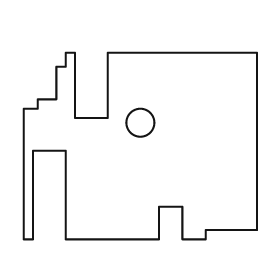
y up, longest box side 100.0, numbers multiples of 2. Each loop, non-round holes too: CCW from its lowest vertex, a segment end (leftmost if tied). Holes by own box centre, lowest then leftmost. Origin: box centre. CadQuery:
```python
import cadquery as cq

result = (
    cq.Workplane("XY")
    .moveTo(-50.0, -40.0)
    .lineTo(-46.0, -40.0)
    .lineTo(-46.0, -2.0)
    .lineTo(-32.0, -2.0)
    .lineTo(-32.0, -40.0)
    .lineTo(8.0, -40.0)
    .lineTo(8.0, -26.0)
    .lineTo(18.0, -26.0)
    .lineTo(18.0, -40.0)
    .lineTo(28.0, -40.0)
    .lineTo(28.0, -36.0)
    .lineTo(50.0, -36.0)
    .lineTo(50.0, 40.0)
    .lineTo(-14.0, 40.0)
    .lineTo(-14.0, 12.0)
    .lineTo(-28.0, 12.0)
    .lineTo(-28.0, 40.0)
    .lineTo(-32.0, 40.0)
    .lineTo(-32.0, 34.0)
    .lineTo(-36.0, 34.0)
    .lineTo(-36.0, 20.0)
    .lineTo(-44.0, 20.0)
    .lineTo(-44.0, 16.0)
    .lineTo(-50.0, 16.0)
    .close()
    .moveTo(0.0, 10.0)
    .circle(6.0)
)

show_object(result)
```